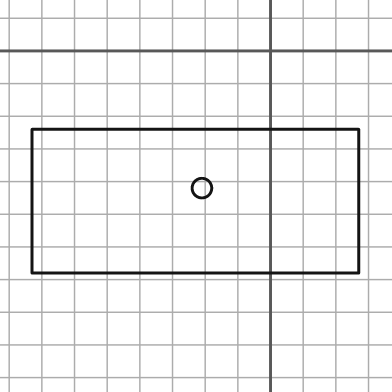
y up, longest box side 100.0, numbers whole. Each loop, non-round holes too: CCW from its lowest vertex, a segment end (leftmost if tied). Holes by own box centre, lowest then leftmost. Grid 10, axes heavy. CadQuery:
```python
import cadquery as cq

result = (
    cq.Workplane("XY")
    .moveTo(-73.0, -68.0)
    .lineTo(27.0, -68.0)
    .lineTo(27.0, -24.0)
    .lineTo(-73.0, -24.0)
    .close()
    .moveTo(-21.0, -42.0)
    .circle(3.0)
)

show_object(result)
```